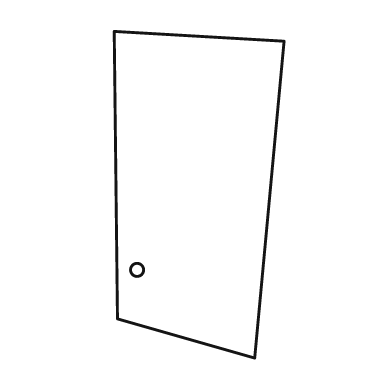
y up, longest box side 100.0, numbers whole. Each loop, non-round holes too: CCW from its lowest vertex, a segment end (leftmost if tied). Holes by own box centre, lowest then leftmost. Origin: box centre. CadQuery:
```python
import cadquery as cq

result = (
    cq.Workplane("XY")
    .moveTo(17.0, -50.0)
    .lineTo(26.0, 47.0)
    .lineTo(-26.0, 50.0)
    .lineTo(-25.0, -38.0)
    .close()
    .moveTo(-19.0, -23.0)
    .circle(2.0)
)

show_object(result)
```